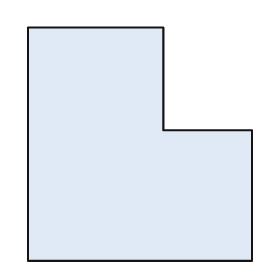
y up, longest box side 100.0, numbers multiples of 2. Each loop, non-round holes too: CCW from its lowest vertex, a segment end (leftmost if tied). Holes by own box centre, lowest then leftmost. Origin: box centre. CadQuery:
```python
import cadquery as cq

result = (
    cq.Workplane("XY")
    .moveTo(-48.0, -50.0)
    .lineTo(48.0, -50.0)
    .lineTo(48.0, 6.0)
    .lineTo(10.0, 6.0)
    .lineTo(10.0, 50.0)
    .lineTo(-48.0, 50.0)
    .close()
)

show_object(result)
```